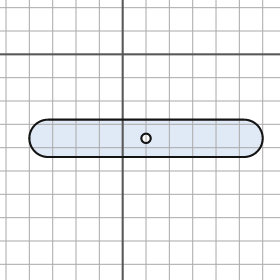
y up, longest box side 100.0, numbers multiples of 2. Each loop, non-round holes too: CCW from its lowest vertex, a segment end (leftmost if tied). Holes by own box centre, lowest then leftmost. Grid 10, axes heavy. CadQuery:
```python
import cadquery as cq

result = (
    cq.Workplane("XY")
    .moveTo(-32.0, -44.0)
    .lineTo(52.0, -44.0)
    .threePointArc((60.0, -36.0), (52.0, -28.0))
    .lineTo(-32.0, -28.0)
    .threePointArc((-40.0, -36.0), (-32.0, -44.0))
    .close()
    .moveTo(10.0, -36.0)
    .circle(2.0)
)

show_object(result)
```